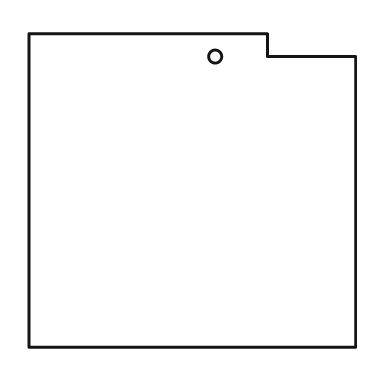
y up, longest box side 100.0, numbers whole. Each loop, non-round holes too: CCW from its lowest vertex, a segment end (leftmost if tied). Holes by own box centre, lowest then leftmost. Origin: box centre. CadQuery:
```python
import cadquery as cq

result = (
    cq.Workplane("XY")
    .moveTo(-50.0, -48.0)
    .lineTo(50.0, -48.0)
    .lineTo(50.0, 41.0)
    .lineTo(23.0, 41.0)
    .lineTo(23.0, 48.0)
    .lineTo(-50.0, 48.0)
    .close()
    .moveTo(7.0, 41.0)
    .circle(2.0)
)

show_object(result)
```